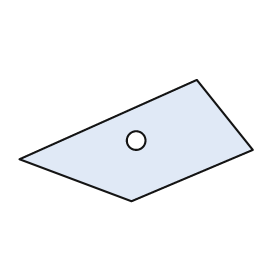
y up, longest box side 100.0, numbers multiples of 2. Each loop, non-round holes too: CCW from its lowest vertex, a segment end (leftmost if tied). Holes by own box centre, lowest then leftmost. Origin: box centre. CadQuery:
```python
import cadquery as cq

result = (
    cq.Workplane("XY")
    .moveTo(-2.0, -26.0)
    .lineTo(50.0, -4.0)
    .lineTo(26.0, 26.0)
    .lineTo(-50.0, -8.0)
    .close()
    .moveTo(0.0, 0.0)
    .circle(4.0)
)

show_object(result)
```